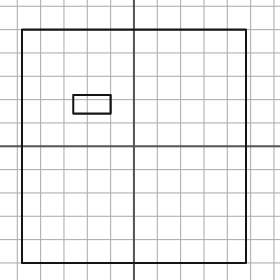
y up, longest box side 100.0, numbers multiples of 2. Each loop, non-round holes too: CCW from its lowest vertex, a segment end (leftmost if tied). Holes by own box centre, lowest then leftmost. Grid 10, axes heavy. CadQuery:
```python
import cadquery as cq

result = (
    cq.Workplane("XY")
    .moveTo(-48.0, -50.0)
    .lineTo(48.0, -50.0)
    .lineTo(48.0, 50.0)
    .lineTo(-48.0, 50.0)
    .close()
    .moveTo(-26.0, 14.0)
    .lineTo(-10.0, 14.0)
    .lineTo(-10.0, 22.0)
    .lineTo(-26.0, 22.0)
    .close()
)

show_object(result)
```